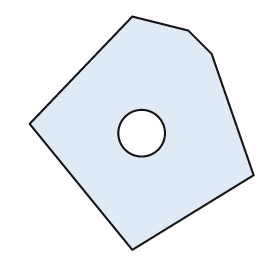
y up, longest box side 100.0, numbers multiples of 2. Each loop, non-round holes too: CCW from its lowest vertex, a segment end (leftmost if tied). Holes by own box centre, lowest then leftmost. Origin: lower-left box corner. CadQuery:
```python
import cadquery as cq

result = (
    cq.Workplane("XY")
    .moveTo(44.0, 0.0)
    .lineTo(96.0, 32.0)
    .lineTo(78.0, 84.0)
    .lineTo(68.0, 94.0)
    .lineTo(44.0, 100.0)
    .lineTo(0.0, 54.0)
    .close()
    .moveTo(48.0, 50.0)
    .circle(10.0)
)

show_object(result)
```